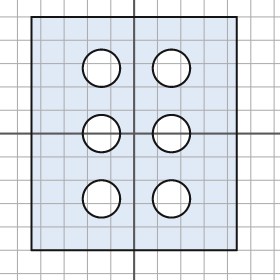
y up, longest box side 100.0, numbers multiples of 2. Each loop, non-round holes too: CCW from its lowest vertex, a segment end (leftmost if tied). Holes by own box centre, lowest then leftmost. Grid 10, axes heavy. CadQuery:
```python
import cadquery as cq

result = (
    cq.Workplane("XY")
    .moveTo(-44.0, -50.0)
    .lineTo(44.0, -50.0)
    .lineTo(44.0, 50.0)
    .lineTo(-44.0, 50.0)
    .close()
    .moveTo(-14.0, -28.0)
    .circle(8.0)
    .moveTo(16.0, -28.0)
    .circle(8.0)
    .moveTo(-14.0, 0.0)
    .circle(8.0)
    .moveTo(16.0, 0.0)
    .circle(8.0)
    .moveTo(-14.0, 28.0)
    .circle(8.0)
    .moveTo(16.0, 28.0)
    .circle(8.0)
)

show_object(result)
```